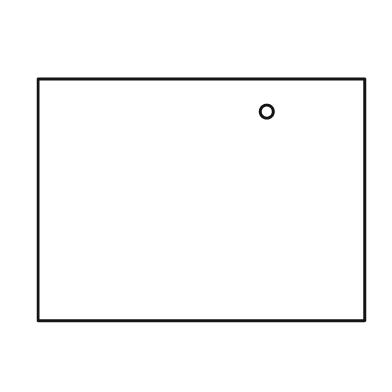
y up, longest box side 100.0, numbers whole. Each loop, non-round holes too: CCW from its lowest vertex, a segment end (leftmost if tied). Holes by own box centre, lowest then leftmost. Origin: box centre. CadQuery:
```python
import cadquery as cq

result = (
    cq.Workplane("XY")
    .moveTo(-50.0, -37.0)
    .lineTo(50.0, -37.0)
    .lineTo(50.0, 37.0)
    .lineTo(-50.0, 37.0)
    .close()
    .moveTo(20.0, 27.0)
    .circle(2.0)
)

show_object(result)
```